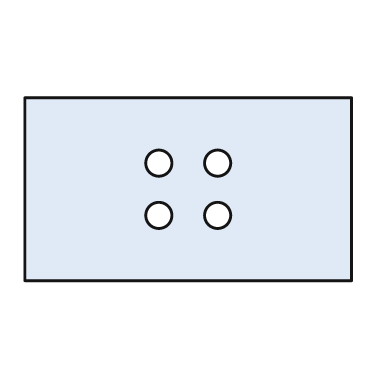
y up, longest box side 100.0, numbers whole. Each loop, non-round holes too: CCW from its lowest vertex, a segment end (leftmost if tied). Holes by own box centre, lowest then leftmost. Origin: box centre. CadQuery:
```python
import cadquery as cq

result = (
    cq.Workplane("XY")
    .moveTo(-50.0, -28.0)
    .lineTo(50.0, -28.0)
    .lineTo(50.0, 28.0)
    .lineTo(-50.0, 28.0)
    .close()
    .moveTo(-9.0, -8.0)
    .circle(4.0)
    .moveTo(9.0, -8.0)
    .circle(4.0)
    .moveTo(-9.0, 8.0)
    .circle(4.0)
    .moveTo(9.0, 8.0)
    .circle(4.0)
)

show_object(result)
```